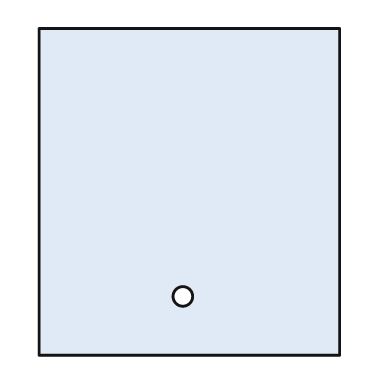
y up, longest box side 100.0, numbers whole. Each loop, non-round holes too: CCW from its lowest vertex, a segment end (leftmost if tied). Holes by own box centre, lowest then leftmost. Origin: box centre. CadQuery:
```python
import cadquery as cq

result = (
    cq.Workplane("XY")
    .moveTo(-46.0, -50.0)
    .lineTo(46.0, -50.0)
    .lineTo(46.0, 50.0)
    .lineTo(-46.0, 50.0)
    .close()
    .moveTo(-2.0, -32.0)
    .circle(3.0)
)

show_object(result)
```